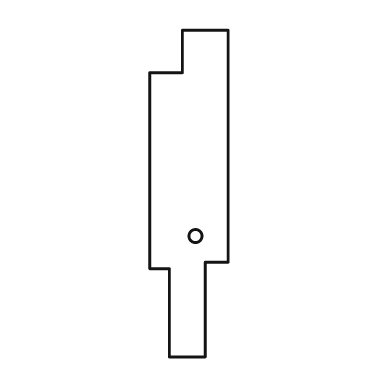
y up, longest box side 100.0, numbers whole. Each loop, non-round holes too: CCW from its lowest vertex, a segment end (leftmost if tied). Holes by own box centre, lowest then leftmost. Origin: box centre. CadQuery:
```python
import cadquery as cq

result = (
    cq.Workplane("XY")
    .moveTo(-6.0, -50.0)
    .lineTo(5.0, -50.0)
    .lineTo(5.0, -21.0)
    .lineTo(12.0, -21.0)
    .lineTo(12.0, 50.0)
    .lineTo(-2.0, 50.0)
    .lineTo(-2.0, 37.0)
    .lineTo(-12.0, 37.0)
    .lineTo(-12.0, -23.0)
    .lineTo(-6.0, -23.0)
    .close()
    .moveTo(2.0, -13.0)
    .circle(2.0)
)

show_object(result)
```